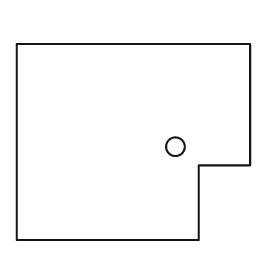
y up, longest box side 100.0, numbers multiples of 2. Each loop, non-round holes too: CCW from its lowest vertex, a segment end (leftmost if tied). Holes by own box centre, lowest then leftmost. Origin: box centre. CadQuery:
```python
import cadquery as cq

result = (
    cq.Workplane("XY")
    .moveTo(-50.0, -42.0)
    .lineTo(28.0, -42.0)
    .lineTo(28.0, -10.0)
    .lineTo(50.0, -10.0)
    .lineTo(50.0, 42.0)
    .lineTo(-50.0, 42.0)
    .close()
    .moveTo(18.0, -2.0)
    .circle(4.0)
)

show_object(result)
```